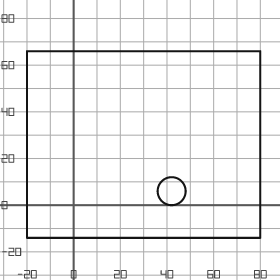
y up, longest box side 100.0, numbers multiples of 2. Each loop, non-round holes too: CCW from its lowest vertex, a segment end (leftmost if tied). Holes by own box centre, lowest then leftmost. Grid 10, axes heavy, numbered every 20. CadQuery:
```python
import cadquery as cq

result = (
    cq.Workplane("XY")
    .moveTo(-20.0, -14.0)
    .lineTo(80.0, -14.0)
    .lineTo(80.0, 66.0)
    .lineTo(-20.0, 66.0)
    .close()
    .moveTo(42.0, 6.0)
    .circle(6.0)
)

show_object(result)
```